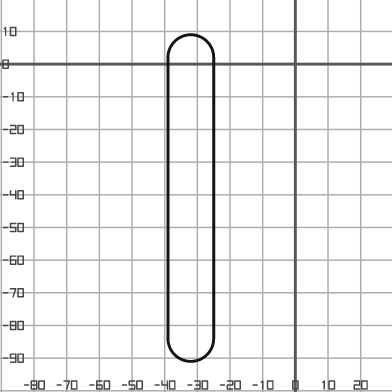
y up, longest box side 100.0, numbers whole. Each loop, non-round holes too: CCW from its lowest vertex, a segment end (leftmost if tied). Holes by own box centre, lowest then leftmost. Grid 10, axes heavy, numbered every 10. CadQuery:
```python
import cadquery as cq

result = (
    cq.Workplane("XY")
    .moveTo(-39.0, -84.0)
    .threePointArc((-32.0, -91.0), (-25.0, -84.0))
    .lineTo(-25.0, 2.0)
    .threePointArc((-32.0, 9.0), (-39.0, 2.0))
    .close()
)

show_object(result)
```